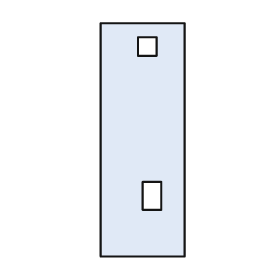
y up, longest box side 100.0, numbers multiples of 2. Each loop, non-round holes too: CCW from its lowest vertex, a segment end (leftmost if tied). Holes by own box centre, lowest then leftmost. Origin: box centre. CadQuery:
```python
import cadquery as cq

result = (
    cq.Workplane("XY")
    .moveTo(-18.0, -50.0)
    .lineTo(18.0, -50.0)
    .lineTo(18.0, 50.0)
    .lineTo(-18.0, 50.0)
    .close()
    .moveTo(0.0, -30.0)
    .lineTo(8.0, -30.0)
    .lineTo(8.0, -18.0)
    .lineTo(0.0, -18.0)
    .close()
    .moveTo(-2.0, 36.0)
    .lineTo(6.0, 36.0)
    .lineTo(6.0, 44.0)
    .lineTo(-2.0, 44.0)
    .close()
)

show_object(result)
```